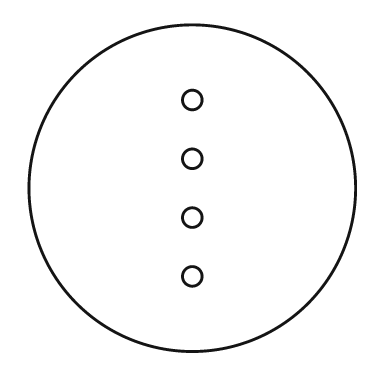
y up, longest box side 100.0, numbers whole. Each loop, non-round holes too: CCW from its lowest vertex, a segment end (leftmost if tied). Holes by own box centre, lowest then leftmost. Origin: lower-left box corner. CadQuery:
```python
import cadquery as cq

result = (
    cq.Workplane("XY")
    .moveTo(50.0, 50.0)
    .circle(50.0)
    .moveTo(50.0, 23.0)
    .circle(3.0)
    .moveTo(50.0, 41.0)
    .circle(3.0)
    .moveTo(50.0, 59.0)
    .circle(3.0)
    .moveTo(50.0, 77.0)
    .circle(3.0)
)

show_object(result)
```